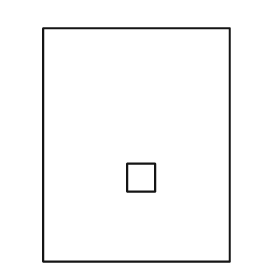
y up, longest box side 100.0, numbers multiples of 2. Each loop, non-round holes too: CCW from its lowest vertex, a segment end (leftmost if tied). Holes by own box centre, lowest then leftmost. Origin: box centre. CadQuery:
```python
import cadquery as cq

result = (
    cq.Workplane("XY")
    .moveTo(-40.0, -50.0)
    .lineTo(40.0, -50.0)
    .lineTo(40.0, 50.0)
    .lineTo(-40.0, 50.0)
    .close()
    .moveTo(-4.0, -20.0)
    .lineTo(8.0, -20.0)
    .lineTo(8.0, -8.0)
    .lineTo(-4.0, -8.0)
    .close()
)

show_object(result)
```